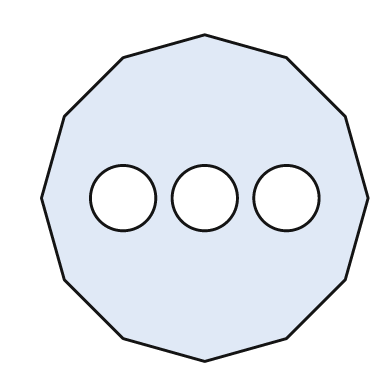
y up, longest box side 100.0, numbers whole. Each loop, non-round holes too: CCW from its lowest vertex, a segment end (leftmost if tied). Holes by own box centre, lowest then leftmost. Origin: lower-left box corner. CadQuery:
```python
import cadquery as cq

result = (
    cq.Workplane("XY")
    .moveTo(50.0, 0.0)
    .lineTo(75.0, 7.0)
    .lineTo(93.0, 25.0)
    .lineTo(100.0, 50.0)
    .lineTo(93.0, 75.0)
    .lineTo(75.0, 93.0)
    .lineTo(50.0, 100.0)
    .lineTo(25.0, 93.0)
    .lineTo(7.0, 75.0)
    .lineTo(0.0, 50.0)
    .lineTo(7.0, 25.0)
    .lineTo(25.0, 7.0)
    .close()
    .moveTo(25.0, 50.0)
    .circle(10.0)
    .moveTo(50.0, 50.0)
    .circle(10.0)
    .moveTo(75.0, 50.0)
    .circle(10.0)
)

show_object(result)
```